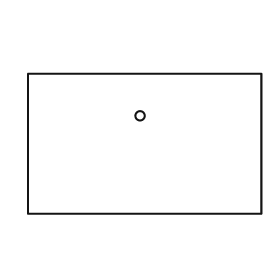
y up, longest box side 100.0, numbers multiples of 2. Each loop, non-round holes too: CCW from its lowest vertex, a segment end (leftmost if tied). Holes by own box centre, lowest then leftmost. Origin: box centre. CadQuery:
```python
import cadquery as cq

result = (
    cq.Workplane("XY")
    .moveTo(-50.0, -30.0)
    .lineTo(50.0, -30.0)
    .lineTo(50.0, 30.0)
    .lineTo(-50.0, 30.0)
    .close()
    .moveTo(-2.0, 12.0)
    .circle(2.0)
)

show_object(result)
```